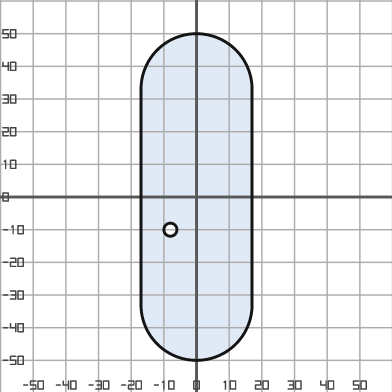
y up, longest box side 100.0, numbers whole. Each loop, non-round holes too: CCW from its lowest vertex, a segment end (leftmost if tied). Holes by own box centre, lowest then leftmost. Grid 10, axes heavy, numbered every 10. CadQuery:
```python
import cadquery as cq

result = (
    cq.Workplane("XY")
    .moveTo(-17.0, -33.0)
    .threePointArc((0.0, -50.0), (17.0, -33.0))
    .lineTo(17.0, 33.0)
    .threePointArc((0.0, 50.0), (-17.0, 33.0))
    .close()
    .moveTo(-8.0, -10.0)
    .circle(2.0)
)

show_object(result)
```